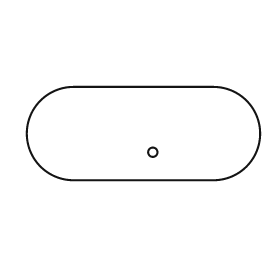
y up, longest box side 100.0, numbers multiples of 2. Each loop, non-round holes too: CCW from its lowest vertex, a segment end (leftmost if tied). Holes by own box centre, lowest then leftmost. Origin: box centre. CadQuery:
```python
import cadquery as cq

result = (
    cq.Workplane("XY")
    .moveTo(-30.0, -20.0)
    .lineTo(30.0, -20.0)
    .threePointArc((50.0, 0.0), (30.0, 20.0))
    .lineTo(-30.0, 20.0)
    .threePointArc((-50.0, 0.0), (-30.0, -20.0))
    .close()
    .moveTo(4.0, -8.0)
    .circle(2.0)
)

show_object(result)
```